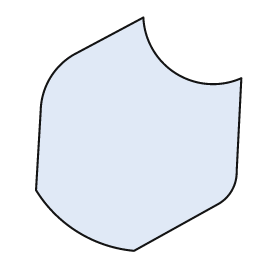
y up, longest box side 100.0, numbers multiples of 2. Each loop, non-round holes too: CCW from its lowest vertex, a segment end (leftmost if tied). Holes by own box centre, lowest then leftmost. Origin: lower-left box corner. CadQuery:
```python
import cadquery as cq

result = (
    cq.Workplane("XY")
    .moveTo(42.0, 0.0)
    .lineTo(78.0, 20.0)
    .threePointArc((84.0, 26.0), (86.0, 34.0))
    .lineTo(88.0, 74.0)
    .threePointArc((60.0, 76.0), (46.0, 100.0))
    .lineTo(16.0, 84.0)
    .threePointArc((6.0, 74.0), (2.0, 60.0))
    .lineTo(0.0, 26.0)
    .threePointArc((18.0, 8.0), (42.0, 0.0))
    .close()
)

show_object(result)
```